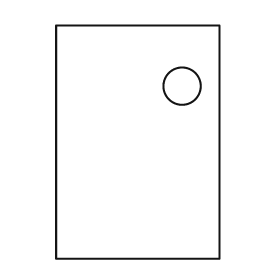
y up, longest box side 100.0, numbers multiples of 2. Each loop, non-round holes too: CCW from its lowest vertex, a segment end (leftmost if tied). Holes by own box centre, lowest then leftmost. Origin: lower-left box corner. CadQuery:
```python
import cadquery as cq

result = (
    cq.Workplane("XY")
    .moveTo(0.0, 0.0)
    .lineTo(70.0, 0.0)
    .lineTo(70.0, 100.0)
    .lineTo(0.0, 100.0)
    .close()
    .moveTo(54.0, 74.0)
    .circle(8.0)
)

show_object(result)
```